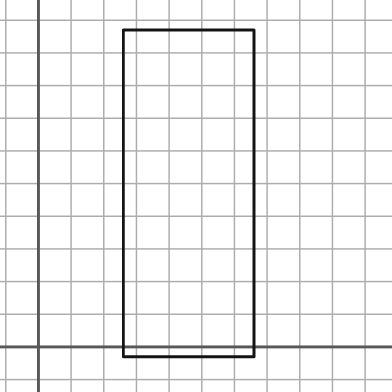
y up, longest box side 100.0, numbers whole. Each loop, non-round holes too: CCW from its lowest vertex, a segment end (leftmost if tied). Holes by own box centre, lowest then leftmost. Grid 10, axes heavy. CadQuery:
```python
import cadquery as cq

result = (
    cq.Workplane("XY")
    .moveTo(26.0, -3.0)
    .lineTo(66.0, -3.0)
    .lineTo(66.0, 97.0)
    .lineTo(26.0, 97.0)
    .close()
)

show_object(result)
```